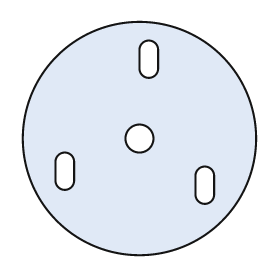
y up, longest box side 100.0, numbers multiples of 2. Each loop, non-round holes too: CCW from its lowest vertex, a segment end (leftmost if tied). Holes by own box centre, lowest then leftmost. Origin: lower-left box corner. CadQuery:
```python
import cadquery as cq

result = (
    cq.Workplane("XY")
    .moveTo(50.0, 50.0)
    .circle(50.0)
    .moveTo(74.0, 26.0)
    .threePointArc((78.0, 22.0), (82.0, 26.0))
    .lineTo(82.0, 34.0)
    .threePointArc((78.0, 38.0), (74.0, 34.0))
    .close()
    .moveTo(14.0, 32.0)
    .threePointArc((18.0, 28.0), (22.0, 32.0))
    .lineTo(22.0, 40.0)
    .threePointArc((18.0, 44.0), (14.0, 40.0))
    .close()
    .moveTo(50.0, 50.0)
    .circle(6.0)
    .moveTo(50.0, 80.0)
    .threePointArc((54.0, 76.0), (58.0, 80.0))
    .lineTo(58.0, 88.0)
    .threePointArc((54.0, 92.0), (50.0, 88.0))
    .close()
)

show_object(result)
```